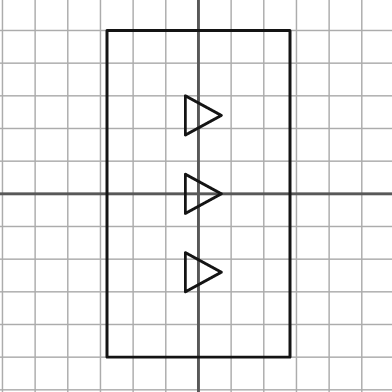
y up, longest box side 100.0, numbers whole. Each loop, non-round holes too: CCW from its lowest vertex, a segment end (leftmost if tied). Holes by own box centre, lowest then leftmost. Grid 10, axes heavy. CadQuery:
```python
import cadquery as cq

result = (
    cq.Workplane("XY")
    .moveTo(-28.0, -50.0)
    .lineTo(28.0, -50.0)
    .lineTo(28.0, 50.0)
    .lineTo(-28.0, 50.0)
    .close()
    .moveTo(-4.0, -30.0)
    .lineTo(7.0, -24.0)
    .lineTo(-4.0, -18.0)
    .close()
    .moveTo(-4.0, -6.0)
    .lineTo(7.0, 0.0)
    .lineTo(-4.0, 6.0)
    .close()
    .moveTo(-4.0, 18.0)
    .lineTo(7.0, 24.0)
    .lineTo(-4.0, 30.0)
    .close()
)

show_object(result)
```